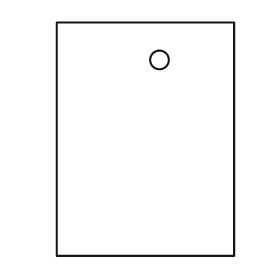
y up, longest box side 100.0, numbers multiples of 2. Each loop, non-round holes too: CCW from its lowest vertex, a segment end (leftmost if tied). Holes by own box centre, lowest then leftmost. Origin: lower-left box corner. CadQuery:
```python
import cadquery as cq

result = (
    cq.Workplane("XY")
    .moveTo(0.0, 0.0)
    .lineTo(76.0, 0.0)
    .lineTo(76.0, 100.0)
    .lineTo(0.0, 100.0)
    .close()
    .moveTo(44.0, 84.0)
    .circle(4.0)
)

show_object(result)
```